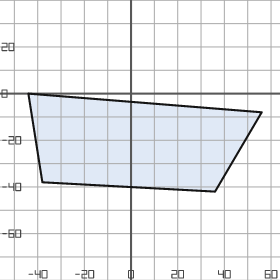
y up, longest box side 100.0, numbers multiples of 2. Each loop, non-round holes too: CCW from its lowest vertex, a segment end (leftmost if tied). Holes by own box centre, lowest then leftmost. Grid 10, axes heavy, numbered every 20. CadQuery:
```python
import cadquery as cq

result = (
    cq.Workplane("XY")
    .moveTo(36.0, -42.0)
    .lineTo(56.0, -8.0)
    .lineTo(-44.0, 0.0)
    .lineTo(-38.0, -38.0)
    .close()
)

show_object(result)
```